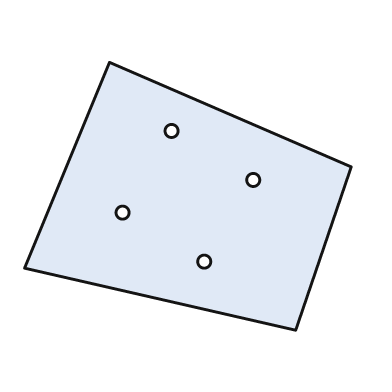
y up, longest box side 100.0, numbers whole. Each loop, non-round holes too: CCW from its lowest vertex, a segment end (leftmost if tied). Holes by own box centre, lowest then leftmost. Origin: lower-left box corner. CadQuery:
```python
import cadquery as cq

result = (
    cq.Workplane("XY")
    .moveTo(83.0, 0.0)
    .lineTo(100.0, 50.0)
    .lineTo(26.0, 82.0)
    .lineTo(0.0, 19.0)
    .close()
    .moveTo(55.0, 21.0)
    .circle(2.0)
    .moveTo(30.0, 36.0)
    .circle(2.0)
    .moveTo(70.0, 46.0)
    .circle(2.0)
    .moveTo(45.0, 61.0)
    .circle(2.0)
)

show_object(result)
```